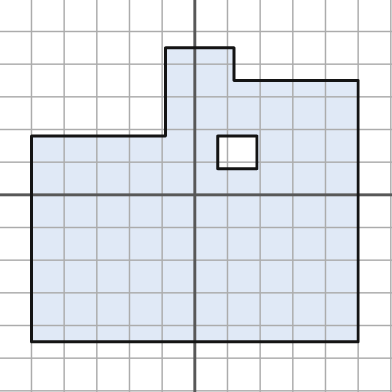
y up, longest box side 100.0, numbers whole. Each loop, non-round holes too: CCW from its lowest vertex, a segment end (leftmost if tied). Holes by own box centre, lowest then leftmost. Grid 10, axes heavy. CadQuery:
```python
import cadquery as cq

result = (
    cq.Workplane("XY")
    .moveTo(-50.0, -45.0)
    .lineTo(50.0, -45.0)
    .lineTo(50.0, 35.0)
    .lineTo(12.0, 35.0)
    .lineTo(12.0, 45.0)
    .lineTo(-9.0, 45.0)
    .lineTo(-9.0, 18.0)
    .lineTo(-50.0, 18.0)
    .close()
    .moveTo(7.0, 8.0)
    .lineTo(19.0, 8.0)
    .lineTo(19.0, 18.0)
    .lineTo(7.0, 18.0)
    .close()
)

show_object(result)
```